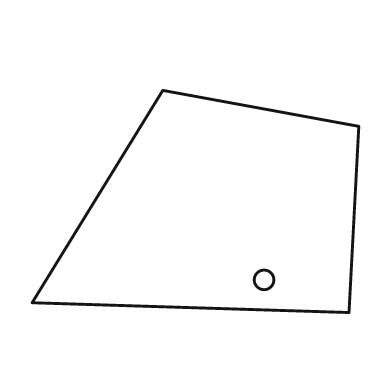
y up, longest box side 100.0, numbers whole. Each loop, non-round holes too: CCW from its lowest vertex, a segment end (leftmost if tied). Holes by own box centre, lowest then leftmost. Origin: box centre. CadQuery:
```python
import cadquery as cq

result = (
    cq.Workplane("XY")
    .moveTo(47.0, -34.0)
    .lineTo(50.0, 23.0)
    .lineTo(-10.0, 34.0)
    .lineTo(-50.0, -31.0)
    .close()
    .moveTo(21.0, -24.0)
    .circle(3.0)
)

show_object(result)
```